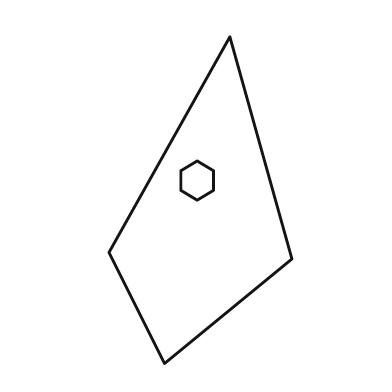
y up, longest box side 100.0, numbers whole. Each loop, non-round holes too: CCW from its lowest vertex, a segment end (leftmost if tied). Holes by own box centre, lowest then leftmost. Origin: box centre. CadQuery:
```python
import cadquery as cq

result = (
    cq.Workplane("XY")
    .moveTo(-11.0, -50.0)
    .lineTo(28.0, -18.0)
    .lineTo(9.0, 50.0)
    .lineTo(-28.0, -16.0)
    .close()
    .moveTo(-1.0, 0.0)
    .lineTo(4.0, 3.0)
    .lineTo(4.0, 9.0)
    .lineTo(-1.0, 12.0)
    .lineTo(-6.0, 9.0)
    .lineTo(-6.0, 3.0)
    .close()
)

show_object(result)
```